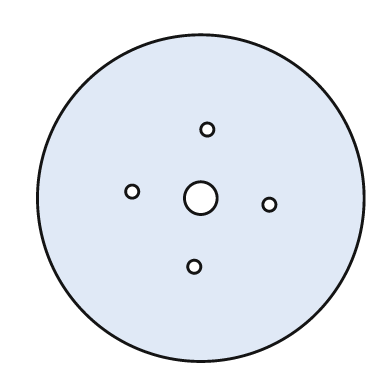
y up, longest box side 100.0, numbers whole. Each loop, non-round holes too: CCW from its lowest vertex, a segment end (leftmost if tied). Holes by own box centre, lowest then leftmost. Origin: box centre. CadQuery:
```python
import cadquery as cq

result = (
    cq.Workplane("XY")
    .moveTo(0.0, 0.0)
    .circle(50.0)
    .moveTo(-2.0, -21.0)
    .circle(2.0)
    .moveTo(21.0, -2.0)
    .circle(2.0)
    .moveTo(0.0, 0.0)
    .circle(5.0)
    .moveTo(-21.0, 2.0)
    .circle(2.0)
    .moveTo(2.0, 21.0)
    .circle(2.0)
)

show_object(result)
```